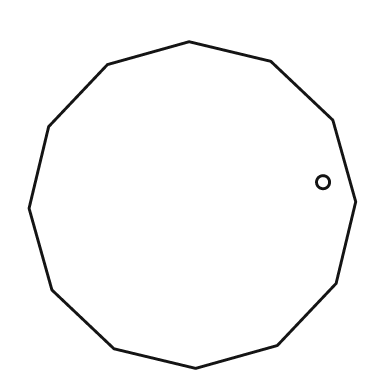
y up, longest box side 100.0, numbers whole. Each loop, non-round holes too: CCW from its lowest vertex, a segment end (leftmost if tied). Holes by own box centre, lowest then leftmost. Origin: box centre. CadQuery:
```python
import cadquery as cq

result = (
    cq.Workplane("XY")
    .moveTo(1.0, -50.0)
    .lineTo(26.0, -43.0)
    .lineTo(44.0, -24.0)
    .lineTo(50.0, 1.0)
    .lineTo(43.0, 26.0)
    .lineTo(24.0, 44.0)
    .lineTo(-1.0, 50.0)
    .lineTo(-26.0, 43.0)
    .lineTo(-44.0, 24.0)
    .lineTo(-50.0, -1.0)
    .lineTo(-43.0, -26.0)
    .lineTo(-24.0, -44.0)
    .close()
    .moveTo(40.0, 7.0)
    .circle(2.0)
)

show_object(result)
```